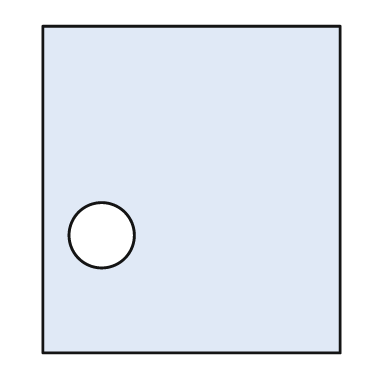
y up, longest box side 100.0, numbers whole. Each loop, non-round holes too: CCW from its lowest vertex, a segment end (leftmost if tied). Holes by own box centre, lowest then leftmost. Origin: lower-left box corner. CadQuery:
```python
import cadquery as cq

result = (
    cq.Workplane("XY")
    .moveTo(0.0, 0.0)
    .lineTo(91.0, 0.0)
    .lineTo(91.0, 100.0)
    .lineTo(0.0, 100.0)
    .close()
    .moveTo(18.0, 36.0)
    .circle(10.0)
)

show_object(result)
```